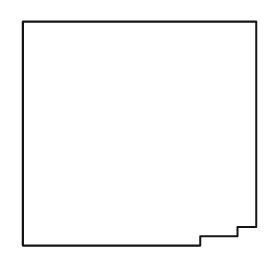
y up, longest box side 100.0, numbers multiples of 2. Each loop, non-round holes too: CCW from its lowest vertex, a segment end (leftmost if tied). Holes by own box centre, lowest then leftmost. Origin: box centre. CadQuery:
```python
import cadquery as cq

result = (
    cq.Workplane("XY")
    .moveTo(-50.0, -48.0)
    .lineTo(26.0, -48.0)
    .lineTo(26.0, -44.0)
    .lineTo(42.0, -44.0)
    .lineTo(42.0, -40.0)
    .lineTo(50.0, -40.0)
    .lineTo(50.0, 48.0)
    .lineTo(-50.0, 48.0)
    .close()
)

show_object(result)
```